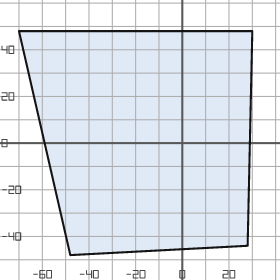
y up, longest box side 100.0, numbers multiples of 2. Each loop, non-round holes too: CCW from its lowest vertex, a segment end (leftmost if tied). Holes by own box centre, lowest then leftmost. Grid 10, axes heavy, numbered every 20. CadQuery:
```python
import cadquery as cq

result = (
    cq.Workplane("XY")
    .moveTo(-48.0, -48.0)
    .lineTo(28.0, -44.0)
    .lineTo(30.0, 48.0)
    .lineTo(-70.0, 48.0)
    .close()
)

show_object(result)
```